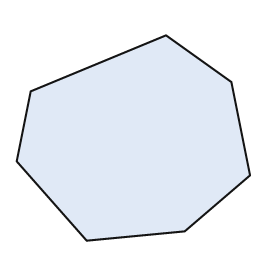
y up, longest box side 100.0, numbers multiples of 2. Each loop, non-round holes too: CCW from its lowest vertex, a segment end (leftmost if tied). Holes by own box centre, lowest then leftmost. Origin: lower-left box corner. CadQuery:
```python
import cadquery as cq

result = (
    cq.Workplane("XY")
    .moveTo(30.0, 0.0)
    .lineTo(72.0, 4.0)
    .lineTo(100.0, 28.0)
    .lineTo(92.0, 68.0)
    .lineTo(64.0, 88.0)
    .lineTo(6.0, 64.0)
    .lineTo(0.0, 34.0)
    .close()
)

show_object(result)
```